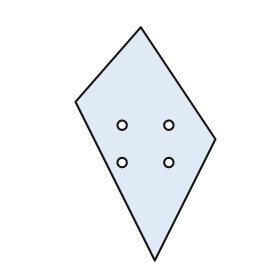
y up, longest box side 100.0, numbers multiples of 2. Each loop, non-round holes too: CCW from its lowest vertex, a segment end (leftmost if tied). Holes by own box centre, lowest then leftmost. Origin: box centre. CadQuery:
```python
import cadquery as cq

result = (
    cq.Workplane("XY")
    .moveTo(4.0, -50.0)
    .lineTo(30.0, 2.0)
    .lineTo(-2.0, 50.0)
    .lineTo(-30.0, 18.0)
    .close()
    .moveTo(-10.0, -8.0)
    .circle(2.0)
    .moveTo(10.0, -8.0)
    .circle(2.0)
    .moveTo(-10.0, 8.0)
    .circle(2.0)
    .moveTo(10.0, 8.0)
    .circle(2.0)
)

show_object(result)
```